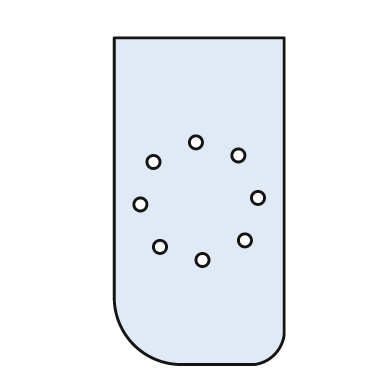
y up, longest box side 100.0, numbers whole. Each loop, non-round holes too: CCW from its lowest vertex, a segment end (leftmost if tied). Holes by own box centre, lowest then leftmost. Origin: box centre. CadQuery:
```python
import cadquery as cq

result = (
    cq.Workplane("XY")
    .moveTo(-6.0, -50.0)
    .lineTo(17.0, -50.0)
    .threePointArc((23.0, -47.0), (26.0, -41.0))
    .lineTo(26.0, 50.0)
    .lineTo(-26.0, 50.0)
    .lineTo(-26.0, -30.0)
    .threePointArc((-20.0, -44.0), (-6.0, -50.0))
    .close()
    .moveTo(1.0, -18.0)
    .circle(2.0)
    .moveTo(-12.0, -14.0)
    .circle(2.0)
    .moveTo(14.0, -12.0)
    .circle(2.0)
    .moveTo(-18.0, -1.0)
    .circle(2.0)
    .moveTo(18.0, 1.0)
    .circle(2.0)
    .moveTo(-14.0, 12.0)
    .circle(2.0)
    .moveTo(12.0, 14.0)
    .circle(2.0)
    .moveTo(-1.0, 18.0)
    .circle(2.0)
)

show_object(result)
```